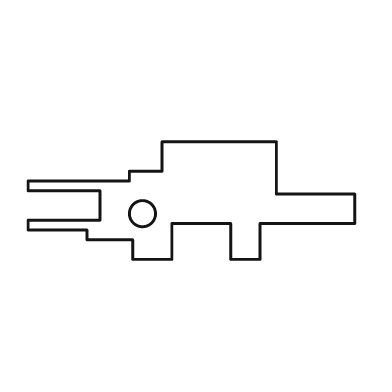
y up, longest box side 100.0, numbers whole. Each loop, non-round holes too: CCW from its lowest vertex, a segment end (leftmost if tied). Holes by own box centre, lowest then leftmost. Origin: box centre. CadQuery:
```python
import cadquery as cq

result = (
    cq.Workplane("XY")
    .moveTo(-18.0, -18.0)
    .lineTo(-6.0, -18.0)
    .lineTo(-6.0, -7.0)
    .lineTo(12.0, -7.0)
    .lineTo(12.0, -18.0)
    .lineTo(21.0, -18.0)
    .lineTo(21.0, -7.0)
    .lineTo(50.0, -7.0)
    .lineTo(50.0, 2.0)
    .lineTo(26.0, 2.0)
    .lineTo(26.0, 18.0)
    .lineTo(-9.0, 18.0)
    .lineTo(-9.0, 9.0)
    .lineTo(-19.0, 9.0)
    .lineTo(-19.0, 6.0)
    .lineTo(-50.0, 6.0)
    .lineTo(-50.0, 3.0)
    .lineTo(-28.0, 3.0)
    .lineTo(-28.0, -6.0)
    .lineTo(-50.0, -6.0)
    .lineTo(-50.0, -9.0)
    .lineTo(-32.0, -9.0)
    .lineTo(-32.0, -12.0)
    .lineTo(-18.0, -12.0)
    .close()
    .moveTo(-15.0, -4.0)
    .circle(4.0)
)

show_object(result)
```